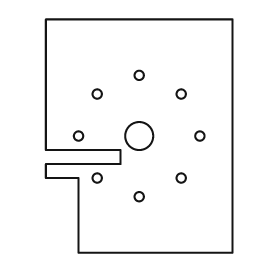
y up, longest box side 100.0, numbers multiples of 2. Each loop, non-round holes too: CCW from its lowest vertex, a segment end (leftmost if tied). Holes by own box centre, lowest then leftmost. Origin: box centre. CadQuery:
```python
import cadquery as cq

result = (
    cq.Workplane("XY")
    .moveTo(-26.0, -50.0)
    .lineTo(40.0, -50.0)
    .lineTo(40.0, 50.0)
    .lineTo(-40.0, 50.0)
    .lineTo(-40.0, -6.0)
    .lineTo(-8.0, -6.0)
    .lineTo(-8.0, -12.0)
    .lineTo(-40.0, -12.0)
    .lineTo(-40.0, -18.0)
    .lineTo(-26.0, -18.0)
    .close()
    .moveTo(0.0, -26.0)
    .circle(2.0)
    .moveTo(-18.0, -18.0)
    .circle(2.0)
    .moveTo(18.0, -18.0)
    .circle(2.0)
    .moveTo(-26.0, 0.0)
    .circle(2.0)
    .moveTo(0.0, 0.0)
    .circle(6.0)
    .moveTo(26.0, 0.0)
    .circle(2.0)
    .moveTo(-18.0, 18.0)
    .circle(2.0)
    .moveTo(18.0, 18.0)
    .circle(2.0)
    .moveTo(0.0, 26.0)
    .circle(2.0)
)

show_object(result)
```